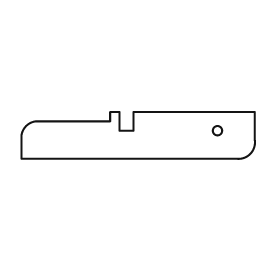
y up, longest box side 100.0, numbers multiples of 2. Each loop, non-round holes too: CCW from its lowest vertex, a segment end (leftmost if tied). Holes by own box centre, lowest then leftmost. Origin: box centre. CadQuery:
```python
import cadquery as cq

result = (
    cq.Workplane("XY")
    .moveTo(-50.0, -10.0)
    .lineTo(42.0, -10.0)
    .threePointArc((48.0, -8.0), (50.0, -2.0))
    .lineTo(50.0, 10.0)
    .lineTo(-2.0, 10.0)
    .lineTo(-2.0, 2.0)
    .lineTo(-8.0, 2.0)
    .lineTo(-8.0, 10.0)
    .lineTo(-12.0, 10.0)
    .lineTo(-12.0, 6.0)
    .lineTo(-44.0, 6.0)
    .threePointArc((-48.0, 4.0), (-50.0, 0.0))
    .close()
    .moveTo(34.0, 2.0)
    .circle(2.0)
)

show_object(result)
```